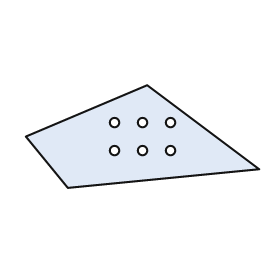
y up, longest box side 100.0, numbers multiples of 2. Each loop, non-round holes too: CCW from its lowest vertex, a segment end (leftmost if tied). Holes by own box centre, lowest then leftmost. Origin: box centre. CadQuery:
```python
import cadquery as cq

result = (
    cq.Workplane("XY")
    .moveTo(-32.0, -22.0)
    .lineTo(50.0, -14.0)
    .lineTo(2.0, 22.0)
    .lineTo(-50.0, 0.0)
    .close()
    .moveTo(-12.0, -6.0)
    .circle(2.0)
    .moveTo(0.0, -6.0)
    .circle(2.0)
    .moveTo(12.0, -6.0)
    .circle(2.0)
    .moveTo(-12.0, 6.0)
    .circle(2.0)
    .moveTo(0.0, 6.0)
    .circle(2.0)
    .moveTo(12.0, 6.0)
    .circle(2.0)
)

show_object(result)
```